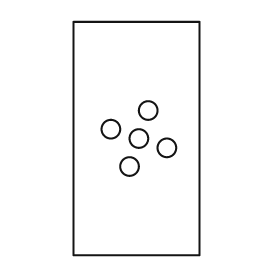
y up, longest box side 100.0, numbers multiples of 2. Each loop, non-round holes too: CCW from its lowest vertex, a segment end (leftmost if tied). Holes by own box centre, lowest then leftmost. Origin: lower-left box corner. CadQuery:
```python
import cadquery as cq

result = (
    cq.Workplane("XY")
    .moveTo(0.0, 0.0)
    .lineTo(54.0, 0.0)
    .lineTo(54.0, 100.0)
    .lineTo(0.0, 100.0)
    .close()
    .moveTo(24.0, 38.0)
    .circle(4.0)
    .moveTo(40.0, 46.0)
    .circle(4.0)
    .moveTo(28.0, 50.0)
    .circle(4.0)
    .moveTo(16.0, 54.0)
    .circle(4.0)
    .moveTo(32.0, 62.0)
    .circle(4.0)
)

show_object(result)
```